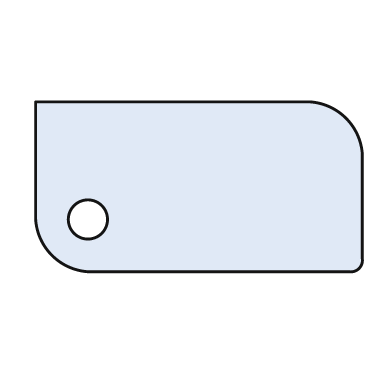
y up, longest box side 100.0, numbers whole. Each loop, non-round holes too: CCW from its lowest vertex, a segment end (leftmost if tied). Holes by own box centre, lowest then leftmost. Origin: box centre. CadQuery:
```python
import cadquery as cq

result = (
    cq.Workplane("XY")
    .moveTo(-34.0, -26.0)
    .lineTo(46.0, -26.0)
    .threePointArc((49.0, -25.0), (50.0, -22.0))
    .lineTo(50.0, 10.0)
    .threePointArc((45.0, 21.0), (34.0, 26.0))
    .lineTo(-50.0, 26.0)
    .lineTo(-50.0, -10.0)
    .threePointArc((-45.0, -21.0), (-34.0, -26.0))
    .close()
    .moveTo(-34.0, -10.0)
    .circle(6.0)
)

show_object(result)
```